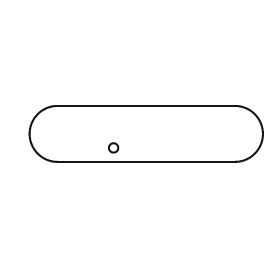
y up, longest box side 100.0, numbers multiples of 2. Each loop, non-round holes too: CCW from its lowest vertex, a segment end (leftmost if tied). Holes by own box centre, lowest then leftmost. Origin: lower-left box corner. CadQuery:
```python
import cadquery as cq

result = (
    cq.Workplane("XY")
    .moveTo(12.0, 0.0)
    .lineTo(88.0, 0.0)
    .threePointArc((100.0, 12.0), (88.0, 24.0))
    .lineTo(12.0, 24.0)
    .threePointArc((0.0, 12.0), (12.0, 0.0))
    .close()
    .moveTo(36.0, 6.0)
    .circle(2.0)
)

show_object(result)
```